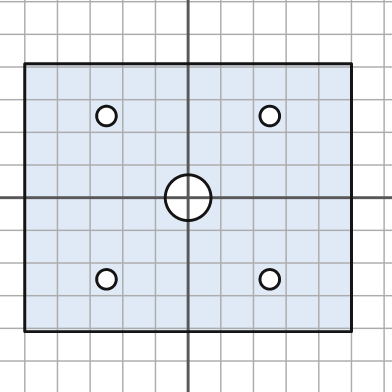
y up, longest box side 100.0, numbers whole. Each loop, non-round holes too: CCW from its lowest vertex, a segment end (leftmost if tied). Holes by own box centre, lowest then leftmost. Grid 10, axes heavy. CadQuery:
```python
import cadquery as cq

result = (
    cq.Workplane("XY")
    .moveTo(-50.0, -41.0)
    .lineTo(50.0, -41.0)
    .lineTo(50.0, 41.0)
    .lineTo(-50.0, 41.0)
    .close()
    .moveTo(-25.0, -25.0)
    .circle(3.0)
    .moveTo(25.0, -25.0)
    .circle(3.0)
    .moveTo(0.0, 0.0)
    .circle(7.0)
    .moveTo(-25.0, 25.0)
    .circle(3.0)
    .moveTo(25.0, 25.0)
    .circle(3.0)
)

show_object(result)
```